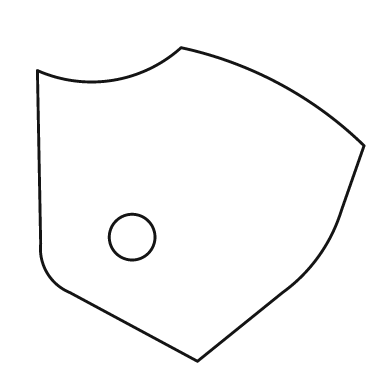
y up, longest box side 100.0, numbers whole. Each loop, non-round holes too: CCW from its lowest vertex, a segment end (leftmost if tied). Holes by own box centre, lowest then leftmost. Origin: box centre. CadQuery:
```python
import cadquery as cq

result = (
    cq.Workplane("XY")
    .moveTo(-1.0, -48.0)
    .lineTo(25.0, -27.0)
    .threePointArc((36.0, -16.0), (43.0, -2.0))
    .lineTo(50.0, 18.0)
    .threePointArc((24.0, 37.0), (-6.0, 48.0))
    .threePointArc((-27.0, 38.0), (-50.0, 41.0))
    .lineTo(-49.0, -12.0)
    .threePointArc((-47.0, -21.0), (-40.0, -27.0))
    .close()
    .moveTo(-21.0, -10.0)
    .circle(7.0)
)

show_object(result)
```